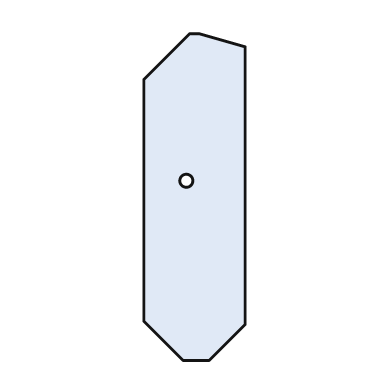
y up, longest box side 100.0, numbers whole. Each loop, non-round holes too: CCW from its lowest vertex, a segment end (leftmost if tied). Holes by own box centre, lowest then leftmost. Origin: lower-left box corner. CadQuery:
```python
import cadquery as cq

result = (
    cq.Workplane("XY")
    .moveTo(12.0, 0.0)
    .lineTo(20.0, 0.0)
    .lineTo(31.0, 11.0)
    .lineTo(31.0, 96.0)
    .lineTo(17.0, 100.0)
    .lineTo(14.0, 100.0)
    .lineTo(0.0, 86.0)
    .lineTo(0.0, 12.0)
    .close()
    .moveTo(13.0, 55.0)
    .circle(2.0)
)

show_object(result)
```